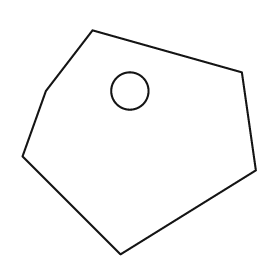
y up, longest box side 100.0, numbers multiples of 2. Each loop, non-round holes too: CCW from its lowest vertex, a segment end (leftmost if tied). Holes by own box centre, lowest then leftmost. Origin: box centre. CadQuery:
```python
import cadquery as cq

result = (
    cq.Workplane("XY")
    .moveTo(-8.0, -48.0)
    .lineTo(50.0, -12.0)
    .lineTo(44.0, 30.0)
    .lineTo(-20.0, 48.0)
    .lineTo(-40.0, 22.0)
    .lineTo(-50.0, -6.0)
    .close()
    .moveTo(-4.0, 22.0)
    .circle(8.0)
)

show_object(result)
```